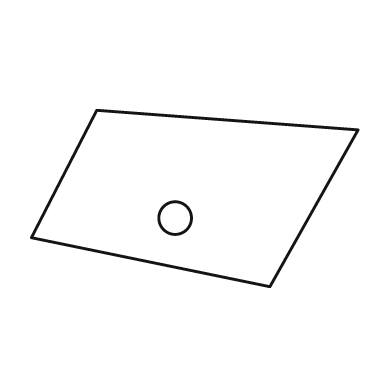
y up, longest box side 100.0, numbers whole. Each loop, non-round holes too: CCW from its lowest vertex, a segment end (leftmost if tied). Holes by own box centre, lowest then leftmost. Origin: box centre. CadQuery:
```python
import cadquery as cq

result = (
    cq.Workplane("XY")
    .moveTo(23.0, -27.0)
    .lineTo(50.0, 21.0)
    .lineTo(-30.0, 27.0)
    .lineTo(-50.0, -12.0)
    .close()
    .moveTo(-6.0, -6.0)
    .circle(5.0)
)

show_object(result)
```